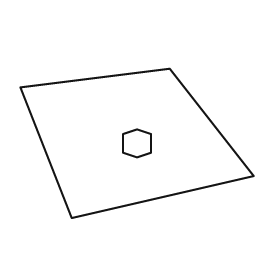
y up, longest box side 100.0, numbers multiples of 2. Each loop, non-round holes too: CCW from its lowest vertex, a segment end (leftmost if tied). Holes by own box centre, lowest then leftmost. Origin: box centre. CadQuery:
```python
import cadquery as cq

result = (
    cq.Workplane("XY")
    .moveTo(-28.0, -32.0)
    .lineTo(50.0, -14.0)
    .lineTo(14.0, 32.0)
    .lineTo(-50.0, 24.0)
    .close()
    .moveTo(0.0, -6.0)
    .lineTo(6.0, -4.0)
    .lineTo(6.0, 4.0)
    .lineTo(0.0, 6.0)
    .lineTo(-6.0, 4.0)
    .lineTo(-6.0, -4.0)
    .close()
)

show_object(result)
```